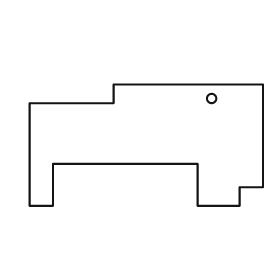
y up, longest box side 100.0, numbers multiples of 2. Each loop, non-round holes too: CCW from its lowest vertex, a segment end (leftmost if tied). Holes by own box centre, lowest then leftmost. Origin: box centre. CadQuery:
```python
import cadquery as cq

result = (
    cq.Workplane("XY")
    .moveTo(-50.0, -26.0)
    .lineTo(-40.0, -26.0)
    .lineTo(-40.0, -8.0)
    .lineTo(22.0, -8.0)
    .lineTo(22.0, -26.0)
    .lineTo(40.0, -26.0)
    .lineTo(40.0, -18.0)
    .lineTo(50.0, -18.0)
    .lineTo(50.0, 26.0)
    .lineTo(-14.0, 26.0)
    .lineTo(-14.0, 18.0)
    .lineTo(-50.0, 18.0)
    .close()
    .moveTo(28.0, 20.0)
    .circle(2.0)
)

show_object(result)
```